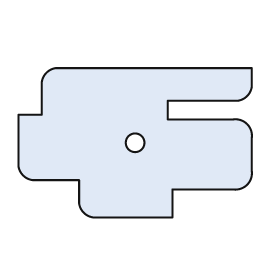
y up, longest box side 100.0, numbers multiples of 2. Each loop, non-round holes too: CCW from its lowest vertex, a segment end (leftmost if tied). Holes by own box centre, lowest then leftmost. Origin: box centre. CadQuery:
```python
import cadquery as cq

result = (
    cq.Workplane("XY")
    .moveTo(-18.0, -32.0)
    .lineTo(16.0, -32.0)
    .lineTo(16.0, -20.0)
    .lineTo(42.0, -20.0)
    .threePointArc((48.0, -18.0), (50.0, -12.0))
    .lineTo(50.0, 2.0)
    .threePointArc((48.0, 8.0), (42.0, 10.0))
    .lineTo(14.0, 10.0)
    .lineTo(14.0, 18.0)
    .lineTo(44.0, 18.0)
    .threePointArc((48.0, 20.0), (50.0, 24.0))
    .lineTo(50.0, 32.0)
    .lineTo(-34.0, 32.0)
    .threePointArc((-38.0, 30.0), (-40.0, 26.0))
    .lineTo(-40.0, 12.0)
    .lineTo(-50.0, 12.0)
    .lineTo(-50.0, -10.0)
    .threePointArc((-48.0, -14.0), (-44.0, -16.0))
    .lineTo(-24.0, -16.0)
    .lineTo(-24.0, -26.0)
    .threePointArc((-22.0, -30.0), (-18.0, -32.0))
    .close()
    .moveTo(0.0, 0.0)
    .circle(4.0)
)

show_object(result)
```